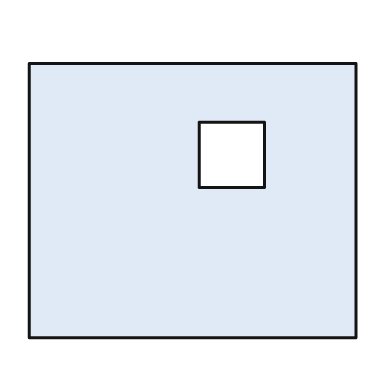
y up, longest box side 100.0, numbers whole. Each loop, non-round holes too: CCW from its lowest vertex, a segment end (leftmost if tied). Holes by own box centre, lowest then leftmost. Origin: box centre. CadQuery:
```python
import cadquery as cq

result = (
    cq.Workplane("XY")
    .moveTo(-50.0, -42.0)
    .lineTo(50.0, -42.0)
    .lineTo(50.0, 42.0)
    .lineTo(-50.0, 42.0)
    .close()
    .moveTo(2.0, 4.0)
    .lineTo(22.0, 4.0)
    .lineTo(22.0, 24.0)
    .lineTo(2.0, 24.0)
    .close()
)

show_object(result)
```